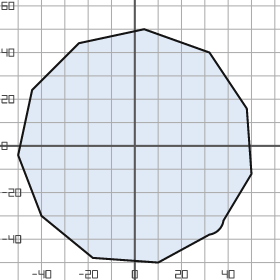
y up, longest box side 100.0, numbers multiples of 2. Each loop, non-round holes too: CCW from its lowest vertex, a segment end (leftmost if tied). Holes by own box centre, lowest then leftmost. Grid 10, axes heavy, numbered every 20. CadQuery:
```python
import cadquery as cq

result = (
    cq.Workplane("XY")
    .moveTo(10.0, -50.0)
    .lineTo(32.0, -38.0)
    .threePointArc((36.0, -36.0), (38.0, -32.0))
    .lineTo(50.0, -12.0)
    .lineTo(48.0, 16.0)
    .lineTo(32.0, 40.0)
    .lineTo(4.0, 50.0)
    .lineTo(-24.0, 44.0)
    .lineTo(-44.0, 24.0)
    .lineTo(-50.0, -4.0)
    .lineTo(-40.0, -30.0)
    .lineTo(-18.0, -48.0)
    .close()
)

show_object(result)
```